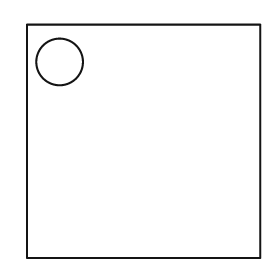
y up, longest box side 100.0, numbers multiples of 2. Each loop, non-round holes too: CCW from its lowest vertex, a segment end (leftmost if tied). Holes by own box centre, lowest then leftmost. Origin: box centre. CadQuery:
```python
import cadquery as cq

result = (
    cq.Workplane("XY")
    .moveTo(-50.0, -50.0)
    .lineTo(50.0, -50.0)
    .lineTo(50.0, 50.0)
    .lineTo(-50.0, 50.0)
    .close()
    .moveTo(-36.0, 34.0)
    .circle(10.0)
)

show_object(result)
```